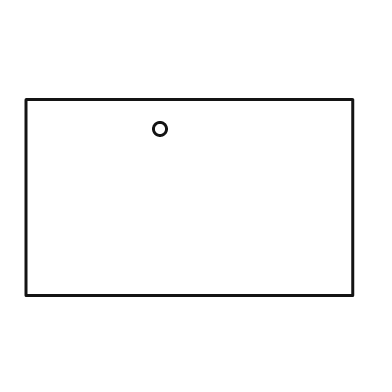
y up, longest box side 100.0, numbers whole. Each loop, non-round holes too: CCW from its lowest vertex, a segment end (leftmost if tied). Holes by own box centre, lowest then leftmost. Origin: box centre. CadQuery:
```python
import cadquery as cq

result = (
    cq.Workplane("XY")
    .moveTo(-50.0, -30.0)
    .lineTo(50.0, -30.0)
    .lineTo(50.0, 30.0)
    .lineTo(-50.0, 30.0)
    .close()
    .moveTo(-9.0, 21.0)
    .circle(2.0)
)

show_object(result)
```